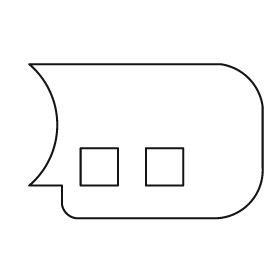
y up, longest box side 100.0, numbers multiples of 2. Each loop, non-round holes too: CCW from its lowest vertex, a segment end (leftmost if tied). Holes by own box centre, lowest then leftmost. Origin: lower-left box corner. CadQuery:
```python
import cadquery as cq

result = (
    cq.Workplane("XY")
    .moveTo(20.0, 0.0)
    .lineTo(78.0, 0.0)
    .threePointArc((94.0, 6.0), (100.0, 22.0))
    .lineTo(100.0, 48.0)
    .threePointArc((94.0, 60.0), (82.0, 66.0))
    .lineTo(0.0, 66.0)
    .threePointArc((12.0, 40.0), (0.0, 14.0))
    .lineTo(14.0, 14.0)
    .lineTo(14.0, 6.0)
    .threePointArc((16.0, 2.0), (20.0, 0.0))
    .close()
    .moveTo(22.0, 14.0)
    .lineTo(38.0, 14.0)
    .lineTo(38.0, 30.0)
    .lineTo(22.0, 30.0)
    .close()
    .moveTo(50.0, 14.0)
    .lineTo(66.0, 14.0)
    .lineTo(66.0, 30.0)
    .lineTo(50.0, 30.0)
    .close()
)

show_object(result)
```